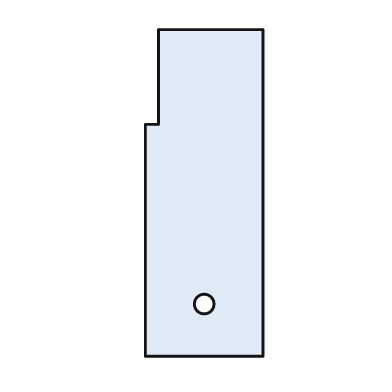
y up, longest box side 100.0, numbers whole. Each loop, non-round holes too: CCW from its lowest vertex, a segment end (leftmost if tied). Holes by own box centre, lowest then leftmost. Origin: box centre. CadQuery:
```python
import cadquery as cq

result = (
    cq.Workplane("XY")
    .moveTo(-18.0, -50.0)
    .lineTo(18.0, -50.0)
    .lineTo(18.0, 50.0)
    .lineTo(-14.0, 50.0)
    .lineTo(-14.0, 21.0)
    .lineTo(-18.0, 21.0)
    .close()
    .moveTo(0.0, -34.0)
    .circle(3.0)
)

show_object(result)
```